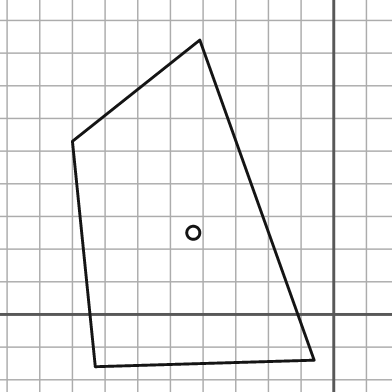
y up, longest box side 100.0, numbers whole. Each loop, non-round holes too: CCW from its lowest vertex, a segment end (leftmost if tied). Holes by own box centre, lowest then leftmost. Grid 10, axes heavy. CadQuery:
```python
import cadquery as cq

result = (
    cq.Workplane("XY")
    .moveTo(-73.0, -16.0)
    .lineTo(-6.0, -14.0)
    .lineTo(-41.0, 84.0)
    .lineTo(-80.0, 53.0)
    .close()
    .moveTo(-43.0, 25.0)
    .circle(2.0)
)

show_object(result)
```